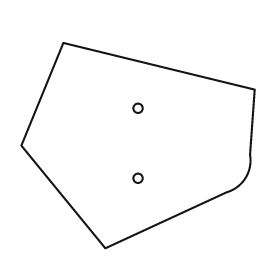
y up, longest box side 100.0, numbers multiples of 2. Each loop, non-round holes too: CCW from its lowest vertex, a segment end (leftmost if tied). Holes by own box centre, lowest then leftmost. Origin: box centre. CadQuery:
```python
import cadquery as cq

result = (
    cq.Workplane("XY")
    .moveTo(-14.0, -44.0)
    .lineTo(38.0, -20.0)
    .threePointArc((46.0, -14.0), (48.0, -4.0))
    .lineTo(50.0, 24.0)
    .lineTo(-32.0, 44.0)
    .lineTo(-50.0, 0.0)
    .close()
    .moveTo(0.0, -14.0)
    .circle(2.0)
    .moveTo(0.0, 16.0)
    .circle(2.0)
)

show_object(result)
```